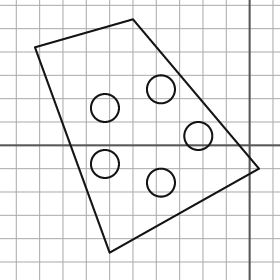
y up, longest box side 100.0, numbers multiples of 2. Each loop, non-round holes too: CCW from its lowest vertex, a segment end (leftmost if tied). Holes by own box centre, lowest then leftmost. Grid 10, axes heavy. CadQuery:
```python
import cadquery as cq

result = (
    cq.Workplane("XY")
    .moveTo(-60.0, -46.0)
    .lineTo(4.0, -10.0)
    .lineTo(-50.0, 54.0)
    .lineTo(-92.0, 42.0)
    .close()
    .moveTo(-38.0, -16.0)
    .circle(6.0)
    .moveTo(-62.0, -8.0)
    .circle(6.0)
    .moveTo(-22.0, 4.0)
    .circle(6.0)
    .moveTo(-62.0, 16.0)
    .circle(6.0)
    .moveTo(-38.0, 24.0)
    .circle(6.0)
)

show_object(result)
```